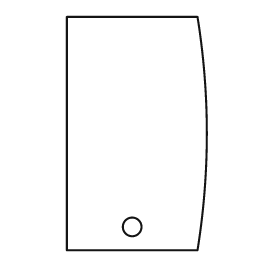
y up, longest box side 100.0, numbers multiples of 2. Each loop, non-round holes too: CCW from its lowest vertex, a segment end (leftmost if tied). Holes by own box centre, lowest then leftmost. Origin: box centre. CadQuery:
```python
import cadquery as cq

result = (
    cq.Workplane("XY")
    .moveTo(-30.0, -50.0)
    .lineTo(26.0, -50.0)
    .threePointArc((30.0, 0.0), (26.0, 50.0))
    .lineTo(-30.0, 50.0)
    .close()
    .moveTo(-2.0, -40.0)
    .circle(4.0)
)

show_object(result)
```